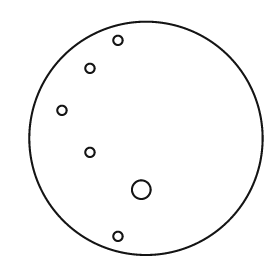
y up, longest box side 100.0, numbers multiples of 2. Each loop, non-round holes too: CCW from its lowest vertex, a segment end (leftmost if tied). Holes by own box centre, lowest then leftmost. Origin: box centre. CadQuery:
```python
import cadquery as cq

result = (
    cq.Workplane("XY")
    .moveTo(0.0, 0.0)
    .circle(50.0)
    .moveTo(-12.0, -42.0)
    .circle(2.0)
    .moveTo(-2.0, -22.0)
    .circle(4.0)
    .moveTo(-24.0, -6.0)
    .circle(2.0)
    .moveTo(-36.0, 12.0)
    .circle(2.0)
    .moveTo(-24.0, 30.0)
    .circle(2.0)
    .moveTo(-12.0, 42.0)
    .circle(2.0)
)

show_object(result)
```